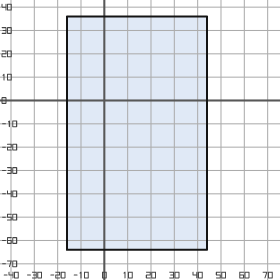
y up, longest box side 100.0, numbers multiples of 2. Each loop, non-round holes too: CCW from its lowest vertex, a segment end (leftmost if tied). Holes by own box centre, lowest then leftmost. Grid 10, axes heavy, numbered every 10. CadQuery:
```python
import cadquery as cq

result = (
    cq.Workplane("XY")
    .moveTo(-16.0, -64.0)
    .lineTo(44.0, -64.0)
    .lineTo(44.0, 36.0)
    .lineTo(-16.0, 36.0)
    .close()
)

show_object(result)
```